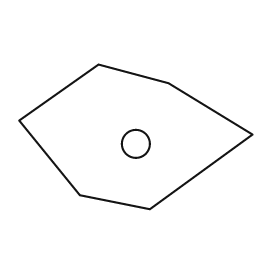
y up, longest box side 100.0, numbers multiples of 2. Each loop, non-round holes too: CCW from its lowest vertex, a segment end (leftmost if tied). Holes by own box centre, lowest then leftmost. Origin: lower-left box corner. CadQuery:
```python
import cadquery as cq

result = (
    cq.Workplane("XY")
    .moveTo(56.0, 0.0)
    .lineTo(100.0, 32.0)
    .lineTo(64.0, 54.0)
    .lineTo(34.0, 62.0)
    .lineTo(0.0, 38.0)
    .lineTo(26.0, 6.0)
    .close()
    .moveTo(50.0, 28.0)
    .circle(6.0)
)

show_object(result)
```